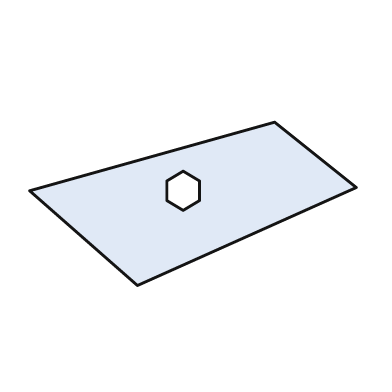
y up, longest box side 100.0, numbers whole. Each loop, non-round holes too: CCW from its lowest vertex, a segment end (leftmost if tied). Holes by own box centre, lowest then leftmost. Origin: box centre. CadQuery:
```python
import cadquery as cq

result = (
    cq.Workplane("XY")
    .moveTo(-17.0, -25.0)
    .lineTo(50.0, 5.0)
    .lineTo(25.0, 25.0)
    .lineTo(-50.0, 4.0)
    .close()
    .moveTo(-3.0, -2.0)
    .lineTo(2.0, 1.0)
    .lineTo(2.0, 7.0)
    .lineTo(-3.0, 10.0)
    .lineTo(-8.0, 7.0)
    .lineTo(-8.0, 1.0)
    .close()
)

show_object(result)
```